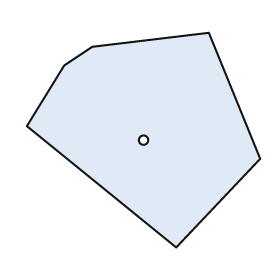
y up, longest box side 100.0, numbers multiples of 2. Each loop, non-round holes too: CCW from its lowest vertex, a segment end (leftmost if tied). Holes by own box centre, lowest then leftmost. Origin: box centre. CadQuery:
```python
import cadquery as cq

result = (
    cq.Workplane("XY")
    .moveTo(14.0, -46.0)
    .lineTo(50.0, -8.0)
    .lineTo(28.0, 46.0)
    .lineTo(-22.0, 40.0)
    .lineTo(-34.0, 32.0)
    .lineTo(-50.0, 6.0)
    .close()
    .moveTo(0.0, 0.0)
    .circle(2.0)
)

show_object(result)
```